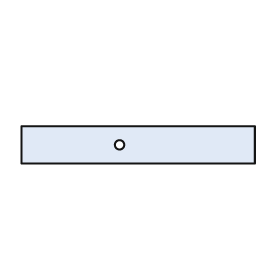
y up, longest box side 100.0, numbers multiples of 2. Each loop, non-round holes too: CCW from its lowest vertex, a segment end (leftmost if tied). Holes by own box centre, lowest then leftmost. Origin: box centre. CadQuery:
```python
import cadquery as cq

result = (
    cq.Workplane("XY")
    .moveTo(-50.0, -8.0)
    .lineTo(50.0, -8.0)
    .lineTo(50.0, 8.0)
    .lineTo(-50.0, 8.0)
    .close()
    .moveTo(-8.0, 0.0)
    .circle(2.0)
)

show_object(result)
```